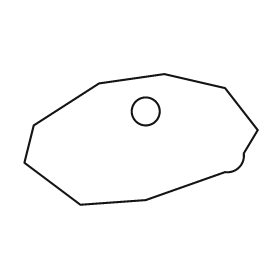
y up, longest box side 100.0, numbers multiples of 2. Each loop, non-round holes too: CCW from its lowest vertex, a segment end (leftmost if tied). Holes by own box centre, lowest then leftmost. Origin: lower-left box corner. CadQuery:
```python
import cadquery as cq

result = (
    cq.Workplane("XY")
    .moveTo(24.0, 0.0)
    .lineTo(52.0, 2.0)
    .lineTo(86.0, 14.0)
    .threePointArc((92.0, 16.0), (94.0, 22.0))
    .lineTo(100.0, 32.0)
    .lineTo(86.0, 50.0)
    .lineTo(60.0, 56.0)
    .lineTo(32.0, 52.0)
    .lineTo(4.0, 34.0)
    .lineTo(0.0, 18.0)
    .close()
    .moveTo(52.0, 40.0)
    .circle(6.0)
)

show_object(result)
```